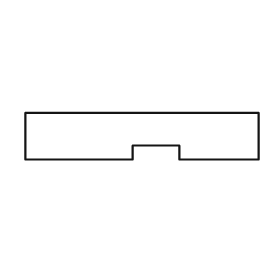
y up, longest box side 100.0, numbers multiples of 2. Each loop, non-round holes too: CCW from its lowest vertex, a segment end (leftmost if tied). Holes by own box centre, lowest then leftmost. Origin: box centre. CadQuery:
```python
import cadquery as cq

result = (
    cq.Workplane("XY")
    .moveTo(-50.0, -10.0)
    .lineTo(-4.0, -10.0)
    .lineTo(-4.0, -4.0)
    .lineTo(16.0, -4.0)
    .lineTo(16.0, -10.0)
    .lineTo(50.0, -10.0)
    .lineTo(50.0, 10.0)
    .lineTo(-50.0, 10.0)
    .close()
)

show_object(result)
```